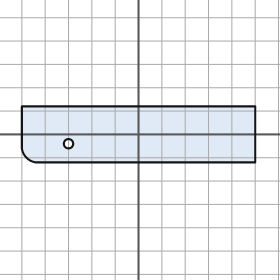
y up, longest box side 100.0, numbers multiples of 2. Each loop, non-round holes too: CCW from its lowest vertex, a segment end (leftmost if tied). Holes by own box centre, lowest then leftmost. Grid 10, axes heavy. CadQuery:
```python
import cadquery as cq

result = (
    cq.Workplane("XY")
    .moveTo(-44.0, -12.0)
    .lineTo(50.0, -12.0)
    .lineTo(50.0, 12.0)
    .lineTo(-50.0, 12.0)
    .lineTo(-50.0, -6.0)
    .threePointArc((-48.0, -10.0), (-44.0, -12.0))
    .close()
    .moveTo(-30.0, -4.0)
    .circle(2.0)
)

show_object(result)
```